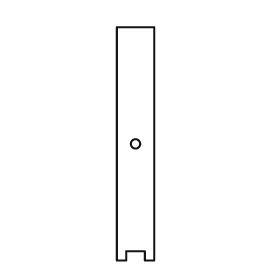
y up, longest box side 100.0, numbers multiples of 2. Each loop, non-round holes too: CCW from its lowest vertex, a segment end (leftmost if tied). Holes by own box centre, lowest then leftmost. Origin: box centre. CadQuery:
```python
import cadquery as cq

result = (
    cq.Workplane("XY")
    .moveTo(-8.0, -50.0)
    .lineTo(-4.0, -50.0)
    .lineTo(-4.0, -46.0)
    .lineTo(4.0, -46.0)
    .lineTo(4.0, -50.0)
    .lineTo(8.0, -50.0)
    .lineTo(8.0, 50.0)
    .lineTo(-8.0, 50.0)
    .close()
    .moveTo(0.0, 0.0)
    .circle(2.0)
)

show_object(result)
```